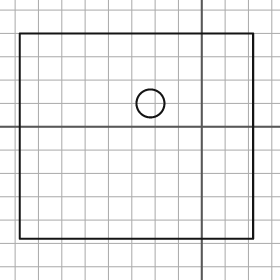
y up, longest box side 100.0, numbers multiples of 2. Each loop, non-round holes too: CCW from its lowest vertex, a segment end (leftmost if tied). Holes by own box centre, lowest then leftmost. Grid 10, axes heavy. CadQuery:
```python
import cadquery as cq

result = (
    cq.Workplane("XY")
    .moveTo(-78.0, -48.0)
    .lineTo(22.0, -48.0)
    .lineTo(22.0, 40.0)
    .lineTo(-78.0, 40.0)
    .close()
    .moveTo(-22.0, 10.0)
    .circle(6.0)
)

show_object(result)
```